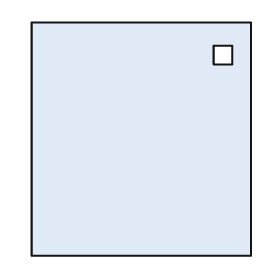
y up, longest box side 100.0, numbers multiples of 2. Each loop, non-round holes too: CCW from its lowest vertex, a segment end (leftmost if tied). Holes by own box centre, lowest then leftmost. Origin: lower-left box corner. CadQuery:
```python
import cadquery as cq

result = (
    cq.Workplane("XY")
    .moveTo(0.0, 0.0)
    .lineTo(94.0, 0.0)
    .lineTo(94.0, 100.0)
    .lineTo(0.0, 100.0)
    .close()
    .moveTo(78.0, 82.0)
    .lineTo(86.0, 82.0)
    .lineTo(86.0, 90.0)
    .lineTo(78.0, 90.0)
    .close()
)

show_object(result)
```